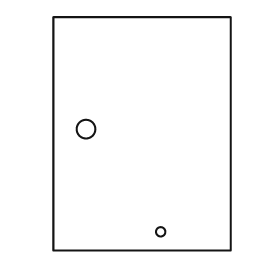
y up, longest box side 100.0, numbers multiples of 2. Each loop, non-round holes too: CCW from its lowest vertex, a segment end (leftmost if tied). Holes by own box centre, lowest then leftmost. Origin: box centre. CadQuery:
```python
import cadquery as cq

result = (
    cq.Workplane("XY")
    .moveTo(-38.0, -50.0)
    .lineTo(38.0, -50.0)
    .lineTo(38.0, 50.0)
    .lineTo(-38.0, 50.0)
    .close()
    .moveTo(8.0, -42.0)
    .circle(2.0)
    .moveTo(-24.0, 2.0)
    .circle(4.0)
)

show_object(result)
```